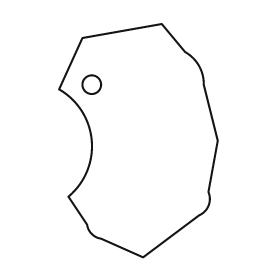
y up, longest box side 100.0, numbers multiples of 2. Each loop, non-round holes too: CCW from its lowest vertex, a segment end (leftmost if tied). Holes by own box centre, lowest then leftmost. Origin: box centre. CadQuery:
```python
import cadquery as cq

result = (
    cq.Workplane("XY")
    .moveTo(2.0, -50.0)
    .lineTo(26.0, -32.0)
    .threePointArc((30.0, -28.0), (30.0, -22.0))
    .lineTo(34.0, 0.0)
    .lineTo(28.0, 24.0)
    .threePointArc((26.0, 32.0), (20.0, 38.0))
    .lineTo(10.0, 50.0)
    .lineTo(-24.0, 44.0)
    .lineTo(-34.0, 22.0)
    .threePointArc((-20.0, 0.0), (-30.0, -24.0))
    .lineTo(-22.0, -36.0)
    .threePointArc((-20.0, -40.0), (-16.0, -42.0))
    .close()
    .moveTo(-20.0, 24.0)
    .circle(4.0)
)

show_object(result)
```